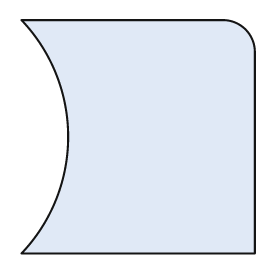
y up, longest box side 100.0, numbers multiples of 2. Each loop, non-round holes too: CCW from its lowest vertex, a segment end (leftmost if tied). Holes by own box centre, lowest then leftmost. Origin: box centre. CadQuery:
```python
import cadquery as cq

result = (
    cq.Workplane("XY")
    .moveTo(-50.0, -50.0)
    .lineTo(50.0, -50.0)
    .lineTo(50.0, 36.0)
    .threePointArc((46.0, 46.0), (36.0, 50.0))
    .lineTo(-50.0, 50.0)
    .threePointArc((-30.0, 0.0), (-50.0, -50.0))
    .close()
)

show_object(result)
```